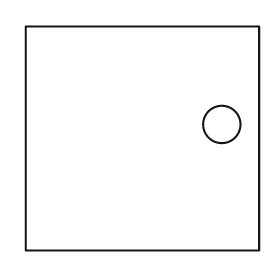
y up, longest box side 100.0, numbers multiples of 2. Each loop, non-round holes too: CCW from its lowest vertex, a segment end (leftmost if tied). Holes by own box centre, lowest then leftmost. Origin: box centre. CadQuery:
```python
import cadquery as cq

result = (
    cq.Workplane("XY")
    .moveTo(-50.0, -48.0)
    .lineTo(50.0, -48.0)
    .lineTo(50.0, 48.0)
    .lineTo(-50.0, 48.0)
    .close()
    .moveTo(34.0, 6.0)
    .circle(8.0)
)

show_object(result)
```